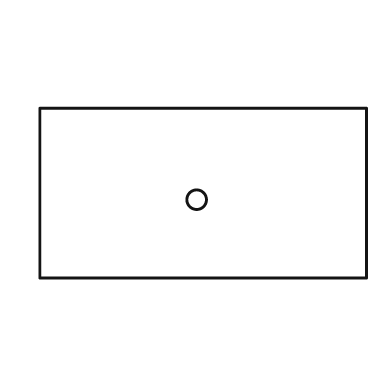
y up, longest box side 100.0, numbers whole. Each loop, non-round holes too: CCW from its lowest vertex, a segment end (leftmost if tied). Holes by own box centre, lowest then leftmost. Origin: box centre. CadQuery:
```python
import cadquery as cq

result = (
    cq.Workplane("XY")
    .moveTo(-50.0, -26.0)
    .lineTo(50.0, -26.0)
    .lineTo(50.0, 26.0)
    .lineTo(-50.0, 26.0)
    .close()
    .moveTo(-2.0, -2.0)
    .circle(3.0)
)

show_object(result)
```